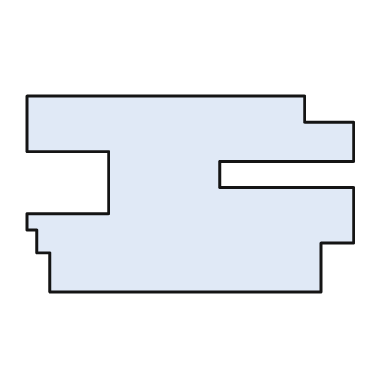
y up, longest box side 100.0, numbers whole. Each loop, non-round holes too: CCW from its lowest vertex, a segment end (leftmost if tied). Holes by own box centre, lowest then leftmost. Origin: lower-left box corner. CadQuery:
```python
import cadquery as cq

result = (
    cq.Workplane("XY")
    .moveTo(7.0, 0.0)
    .lineTo(90.0, 0.0)
    .lineTo(90.0, 15.0)
    .lineTo(100.0, 15.0)
    .lineTo(100.0, 32.0)
    .lineTo(59.0, 32.0)
    .lineTo(59.0, 40.0)
    .lineTo(100.0, 40.0)
    .lineTo(100.0, 52.0)
    .lineTo(85.0, 52.0)
    .lineTo(85.0, 60.0)
    .lineTo(0.0, 60.0)
    .lineTo(0.0, 43.0)
    .lineTo(25.0, 43.0)
    .lineTo(25.0, 24.0)
    .lineTo(0.0, 24.0)
    .lineTo(0.0, 19.0)
    .lineTo(3.0, 19.0)
    .lineTo(3.0, 12.0)
    .lineTo(7.0, 12.0)
    .close()
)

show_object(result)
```